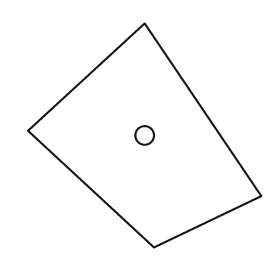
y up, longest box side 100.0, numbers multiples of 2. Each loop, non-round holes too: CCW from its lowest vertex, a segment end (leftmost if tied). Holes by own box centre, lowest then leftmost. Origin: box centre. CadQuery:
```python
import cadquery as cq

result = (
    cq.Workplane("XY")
    .moveTo(4.0, -48.0)
    .lineTo(50.0, -26.0)
    .lineTo(0.0, 48.0)
    .lineTo(-50.0, 2.0)
    .close()
    .moveTo(0.0, 0.0)
    .circle(4.0)
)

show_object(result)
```